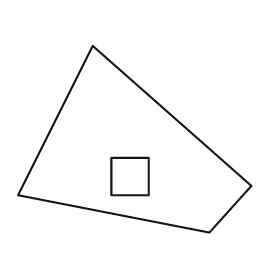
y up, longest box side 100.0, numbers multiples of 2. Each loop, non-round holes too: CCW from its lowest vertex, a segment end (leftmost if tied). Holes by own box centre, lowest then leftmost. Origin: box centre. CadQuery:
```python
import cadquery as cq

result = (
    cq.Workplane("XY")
    .moveTo(32.0, -40.0)
    .lineTo(50.0, -20.0)
    .lineTo(-18.0, 40.0)
    .lineTo(-50.0, -24.0)
    .close()
    .moveTo(-10.0, -24.0)
    .lineTo(6.0, -24.0)
    .lineTo(6.0, -8.0)
    .lineTo(-10.0, -8.0)
    .close()
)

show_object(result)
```